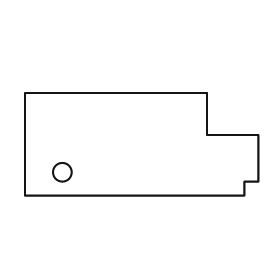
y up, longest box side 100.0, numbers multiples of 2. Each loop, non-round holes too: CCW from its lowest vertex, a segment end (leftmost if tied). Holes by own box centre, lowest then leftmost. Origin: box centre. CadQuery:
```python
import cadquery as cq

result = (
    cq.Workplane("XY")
    .moveTo(-50.0, -22.0)
    .lineTo(44.0, -22.0)
    .lineTo(44.0, -16.0)
    .lineTo(50.0, -16.0)
    .lineTo(50.0, 4.0)
    .lineTo(28.0, 4.0)
    .lineTo(28.0, 22.0)
    .lineTo(-50.0, 22.0)
    .close()
    .moveTo(-34.0, -12.0)
    .circle(4.0)
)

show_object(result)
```